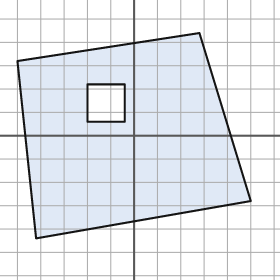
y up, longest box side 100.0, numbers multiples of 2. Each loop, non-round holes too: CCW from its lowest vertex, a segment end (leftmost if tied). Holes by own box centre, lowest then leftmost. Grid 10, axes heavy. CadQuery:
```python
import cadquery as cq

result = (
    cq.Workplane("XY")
    .moveTo(-42.0, -44.0)
    .lineTo(50.0, -28.0)
    .lineTo(28.0, 44.0)
    .lineTo(-50.0, 32.0)
    .close()
    .moveTo(-20.0, 6.0)
    .lineTo(-4.0, 6.0)
    .lineTo(-4.0, 22.0)
    .lineTo(-20.0, 22.0)
    .close()
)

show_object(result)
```